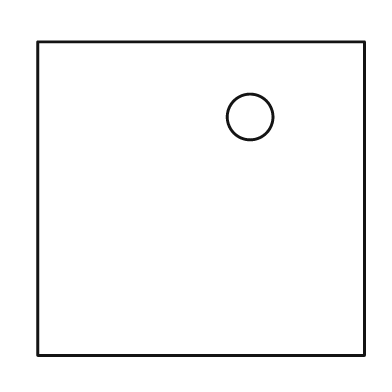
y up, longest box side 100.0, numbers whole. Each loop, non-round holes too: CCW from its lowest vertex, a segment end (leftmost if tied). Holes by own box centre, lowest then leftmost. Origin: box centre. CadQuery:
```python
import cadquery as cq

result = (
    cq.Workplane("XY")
    .moveTo(-50.0, -48.0)
    .lineTo(50.0, -48.0)
    .lineTo(50.0, 48.0)
    .lineTo(-50.0, 48.0)
    .close()
    .moveTo(15.0, 25.0)
    .circle(7.0)
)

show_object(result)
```